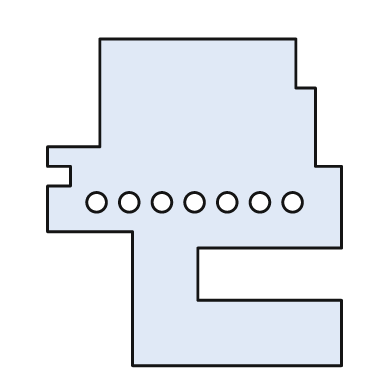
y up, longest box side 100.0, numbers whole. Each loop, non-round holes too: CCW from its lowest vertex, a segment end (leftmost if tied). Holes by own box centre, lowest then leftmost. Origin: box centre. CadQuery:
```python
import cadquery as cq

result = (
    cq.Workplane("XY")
    .moveTo(-19.0, -50.0)
    .lineTo(45.0, -50.0)
    .lineTo(45.0, -30.0)
    .lineTo(1.0, -30.0)
    .lineTo(1.0, -14.0)
    .lineTo(45.0, -14.0)
    .lineTo(45.0, 11.0)
    .lineTo(37.0, 11.0)
    .lineTo(37.0, 35.0)
    .lineTo(31.0, 35.0)
    .lineTo(31.0, 50.0)
    .lineTo(-29.0, 50.0)
    .lineTo(-29.0, 17.0)
    .lineTo(-45.0, 17.0)
    .lineTo(-45.0, 11.0)
    .lineTo(-38.0, 11.0)
    .lineTo(-38.0, 5.0)
    .lineTo(-45.0, 5.0)
    .lineTo(-45.0, -9.0)
    .lineTo(-19.0, -9.0)
    .close()
    .moveTo(-30.0, 0.0)
    .circle(3.0)
    .moveTo(-20.0, 0.0)
    .circle(3.0)
    .moveTo(-10.0, 0.0)
    .circle(3.0)
    .moveTo(0.0, 0.0)
    .circle(3.0)
    .moveTo(10.0, 0.0)
    .circle(3.0)
    .moveTo(20.0, 0.0)
    .circle(3.0)
    .moveTo(30.0, 0.0)
    .circle(3.0)
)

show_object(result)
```